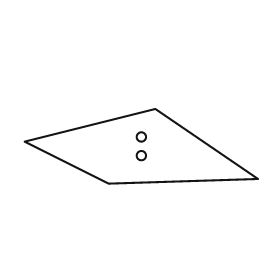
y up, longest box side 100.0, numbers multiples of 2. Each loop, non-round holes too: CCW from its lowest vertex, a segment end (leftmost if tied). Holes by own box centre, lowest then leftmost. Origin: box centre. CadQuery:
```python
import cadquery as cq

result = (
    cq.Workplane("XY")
    .moveTo(-14.0, -16.0)
    .lineTo(50.0, -14.0)
    .lineTo(6.0, 16.0)
    .lineTo(-50.0, 2.0)
    .close()
    .moveTo(0.0, -4.0)
    .circle(2.0)
    .moveTo(0.0, 4.0)
    .circle(2.0)
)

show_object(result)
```